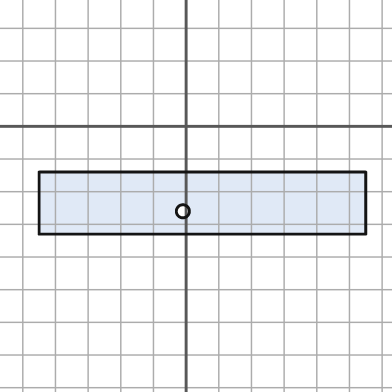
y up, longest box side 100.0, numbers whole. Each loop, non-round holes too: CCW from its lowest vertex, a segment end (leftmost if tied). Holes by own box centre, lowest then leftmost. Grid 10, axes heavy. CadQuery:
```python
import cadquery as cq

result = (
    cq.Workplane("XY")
    .moveTo(-45.0, -33.0)
    .lineTo(55.0, -33.0)
    .lineTo(55.0, -14.0)
    .lineTo(-45.0, -14.0)
    .close()
    .moveTo(-1.0, -26.0)
    .circle(2.0)
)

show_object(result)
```